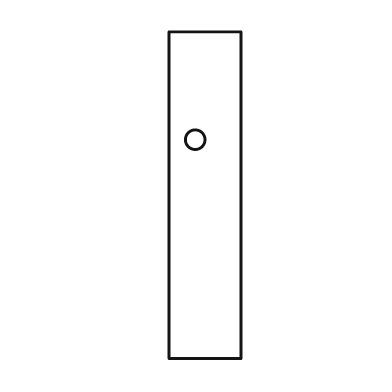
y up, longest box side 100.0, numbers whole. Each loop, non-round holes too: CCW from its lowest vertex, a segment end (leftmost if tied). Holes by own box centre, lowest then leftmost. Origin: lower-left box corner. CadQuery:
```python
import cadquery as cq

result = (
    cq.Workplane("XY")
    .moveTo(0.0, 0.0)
    .lineTo(22.0, 0.0)
    .lineTo(22.0, 100.0)
    .lineTo(0.0, 100.0)
    .close()
    .moveTo(8.0, 67.0)
    .circle(3.0)
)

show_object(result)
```